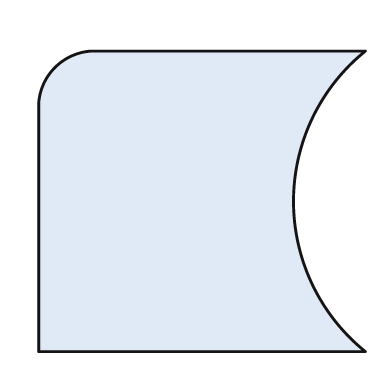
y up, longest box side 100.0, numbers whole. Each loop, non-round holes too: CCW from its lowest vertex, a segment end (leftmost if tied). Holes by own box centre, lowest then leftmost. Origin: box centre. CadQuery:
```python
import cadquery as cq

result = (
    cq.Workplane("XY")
    .moveTo(-50.0, -46.0)
    .lineTo(50.0, -46.0)
    .threePointArc((28.0, 0.0), (50.0, 46.0))
    .lineTo(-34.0, 46.0)
    .threePointArc((-45.0, 41.0), (-50.0, 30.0))
    .close()
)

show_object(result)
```